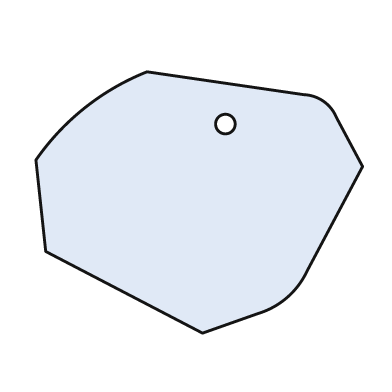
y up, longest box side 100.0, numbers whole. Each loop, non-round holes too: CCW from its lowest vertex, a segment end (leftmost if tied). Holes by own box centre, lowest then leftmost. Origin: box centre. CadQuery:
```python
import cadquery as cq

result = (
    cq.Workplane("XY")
    .moveTo(1.0, -40.0)
    .lineTo(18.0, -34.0)
    .threePointArc((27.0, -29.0), (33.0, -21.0))
    .lineTo(50.0, 11.0)
    .lineTo(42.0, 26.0)
    .threePointArc((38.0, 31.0), (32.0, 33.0))
    .lineTo(-16.0, 40.0)
    .threePointArc((-35.0, 29.0), (-50.0, 13.0))
    .lineTo(-47.0, -15.0)
    .close()
    .moveTo(8.0, 24.0)
    .circle(3.0)
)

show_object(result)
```